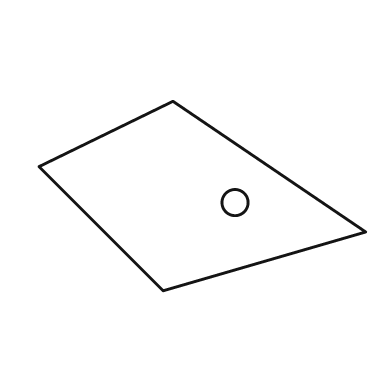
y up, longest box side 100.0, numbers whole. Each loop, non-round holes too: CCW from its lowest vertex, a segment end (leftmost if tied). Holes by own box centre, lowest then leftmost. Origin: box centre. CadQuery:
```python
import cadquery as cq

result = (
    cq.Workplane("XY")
    .moveTo(-12.0, -29.0)
    .lineTo(50.0, -11.0)
    .lineTo(-9.0, 29.0)
    .lineTo(-50.0, 9.0)
    .close()
    .moveTo(10.0, -2.0)
    .circle(4.0)
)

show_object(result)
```